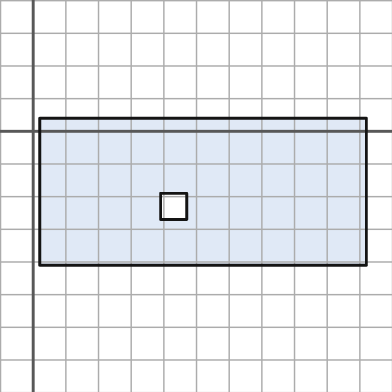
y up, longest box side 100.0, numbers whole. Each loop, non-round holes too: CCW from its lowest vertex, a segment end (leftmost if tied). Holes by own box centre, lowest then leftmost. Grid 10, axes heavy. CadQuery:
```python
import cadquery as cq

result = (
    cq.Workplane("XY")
    .moveTo(2.0, -41.0)
    .lineTo(102.0, -41.0)
    .lineTo(102.0, 4.0)
    .lineTo(2.0, 4.0)
    .close()
    .moveTo(39.0, -27.0)
    .lineTo(47.0, -27.0)
    .lineTo(47.0, -19.0)
    .lineTo(39.0, -19.0)
    .close()
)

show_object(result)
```